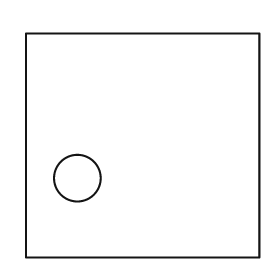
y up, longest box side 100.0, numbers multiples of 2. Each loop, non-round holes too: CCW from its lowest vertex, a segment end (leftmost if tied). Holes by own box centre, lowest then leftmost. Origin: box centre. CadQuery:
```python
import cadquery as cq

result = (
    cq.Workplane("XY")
    .moveTo(-50.0, -48.0)
    .lineTo(50.0, -48.0)
    .lineTo(50.0, 48.0)
    .lineTo(-50.0, 48.0)
    .close()
    .moveTo(-28.0, -14.0)
    .circle(10.0)
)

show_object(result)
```